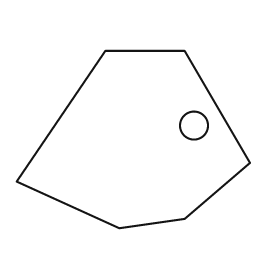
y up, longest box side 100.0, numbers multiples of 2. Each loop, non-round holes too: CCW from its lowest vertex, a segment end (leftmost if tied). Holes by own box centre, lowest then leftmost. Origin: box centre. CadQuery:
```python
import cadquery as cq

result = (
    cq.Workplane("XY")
    .moveTo(-6.0, -38.0)
    .lineTo(22.0, -34.0)
    .lineTo(50.0, -10.0)
    .lineTo(22.0, 38.0)
    .lineTo(-12.0, 38.0)
    .lineTo(-50.0, -18.0)
    .close()
    .moveTo(26.0, 6.0)
    .circle(6.0)
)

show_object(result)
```